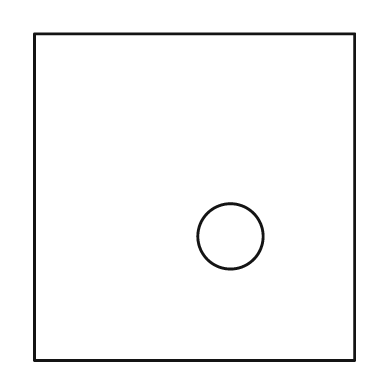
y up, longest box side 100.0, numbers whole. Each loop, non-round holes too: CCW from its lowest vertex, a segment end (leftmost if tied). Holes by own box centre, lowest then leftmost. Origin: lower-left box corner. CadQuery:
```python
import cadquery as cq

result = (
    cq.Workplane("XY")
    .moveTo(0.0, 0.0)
    .lineTo(98.0, 0.0)
    .lineTo(98.0, 100.0)
    .lineTo(0.0, 100.0)
    .close()
    .moveTo(60.0, 38.0)
    .circle(10.0)
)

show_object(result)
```